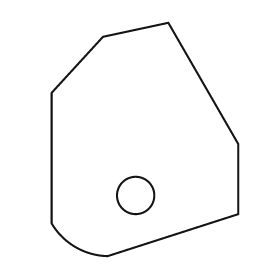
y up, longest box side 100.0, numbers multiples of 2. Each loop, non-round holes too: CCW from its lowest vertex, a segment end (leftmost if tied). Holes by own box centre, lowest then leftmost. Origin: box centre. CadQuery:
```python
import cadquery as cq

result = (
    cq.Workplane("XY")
    .moveTo(-16.0, -50.0)
    .lineTo(40.0, -32.0)
    .lineTo(40.0, -2.0)
    .lineTo(10.0, 50.0)
    .lineTo(-18.0, 44.0)
    .lineTo(-40.0, 20.0)
    .lineTo(-40.0, -36.0)
    .threePointArc((-30.0, -46.0), (-16.0, -50.0))
    .close()
    .moveTo(-4.0, -24.0)
    .circle(8.0)
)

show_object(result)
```